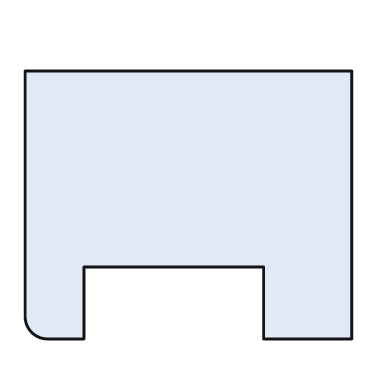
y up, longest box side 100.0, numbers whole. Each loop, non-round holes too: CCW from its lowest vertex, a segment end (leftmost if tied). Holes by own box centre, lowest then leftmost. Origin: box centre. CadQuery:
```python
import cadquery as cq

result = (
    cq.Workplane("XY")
    .moveTo(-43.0, -41.0)
    .lineTo(-32.0, -41.0)
    .lineTo(-32.0, -19.0)
    .lineTo(23.0, -19.0)
    .lineTo(23.0, -41.0)
    .lineTo(50.0, -41.0)
    .lineTo(50.0, 41.0)
    .lineTo(-50.0, 41.0)
    .lineTo(-50.0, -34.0)
    .threePointArc((-48.0, -39.0), (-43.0, -41.0))
    .close()
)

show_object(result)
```